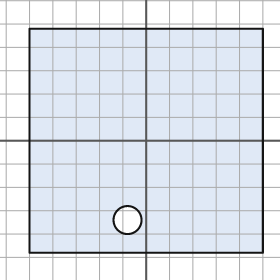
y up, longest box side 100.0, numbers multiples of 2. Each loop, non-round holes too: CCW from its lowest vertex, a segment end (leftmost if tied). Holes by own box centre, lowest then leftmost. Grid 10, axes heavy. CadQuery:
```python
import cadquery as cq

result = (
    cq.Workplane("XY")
    .moveTo(-50.0, -48.0)
    .lineTo(50.0, -48.0)
    .lineTo(50.0, 48.0)
    .lineTo(-50.0, 48.0)
    .close()
    .moveTo(-8.0, -34.0)
    .circle(6.0)
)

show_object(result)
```